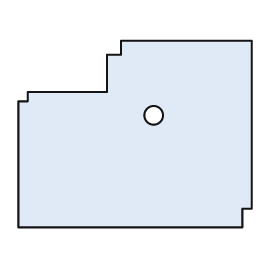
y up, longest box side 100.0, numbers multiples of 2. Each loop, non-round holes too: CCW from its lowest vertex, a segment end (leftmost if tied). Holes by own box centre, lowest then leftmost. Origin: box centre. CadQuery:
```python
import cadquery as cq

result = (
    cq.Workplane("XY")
    .moveTo(-50.0, -40.0)
    .lineTo(46.0, -40.0)
    .lineTo(46.0, -32.0)
    .lineTo(50.0, -32.0)
    .lineTo(50.0, 40.0)
    .lineTo(-6.0, 40.0)
    .lineTo(-6.0, 34.0)
    .lineTo(-12.0, 34.0)
    .lineTo(-12.0, 18.0)
    .lineTo(-46.0, 18.0)
    .lineTo(-46.0, 14.0)
    .lineTo(-50.0, 14.0)
    .close()
    .moveTo(8.0, 8.0)
    .circle(4.0)
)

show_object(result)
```